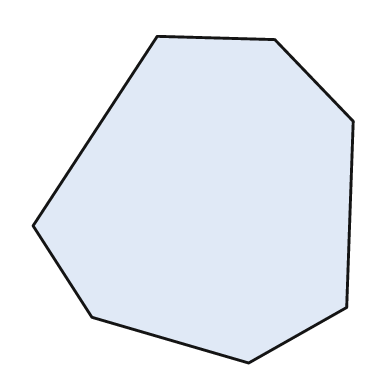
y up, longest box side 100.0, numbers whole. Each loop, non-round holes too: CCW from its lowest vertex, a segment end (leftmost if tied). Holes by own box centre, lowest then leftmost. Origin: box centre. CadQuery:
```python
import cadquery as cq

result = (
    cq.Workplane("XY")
    .moveTo(17.0, -50.0)
    .lineTo(47.0, -33.0)
    .lineTo(49.0, 24.0)
    .lineTo(25.0, 49.0)
    .lineTo(-11.0, 50.0)
    .lineTo(-49.0, -8.0)
    .lineTo(-31.0, -36.0)
    .close()
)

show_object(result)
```